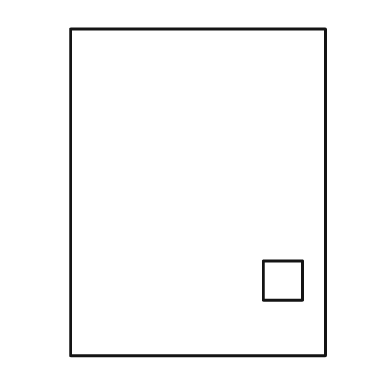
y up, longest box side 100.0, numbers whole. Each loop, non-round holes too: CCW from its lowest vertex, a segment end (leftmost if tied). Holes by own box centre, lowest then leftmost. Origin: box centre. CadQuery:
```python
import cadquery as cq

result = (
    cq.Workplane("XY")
    .moveTo(-39.0, -50.0)
    .lineTo(39.0, -50.0)
    .lineTo(39.0, 50.0)
    .lineTo(-39.0, 50.0)
    .close()
    .moveTo(20.0, -33.0)
    .lineTo(32.0, -33.0)
    .lineTo(32.0, -21.0)
    .lineTo(20.0, -21.0)
    .close()
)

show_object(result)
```